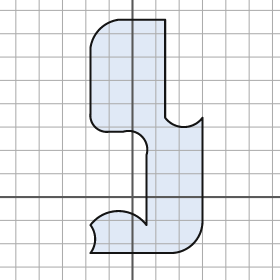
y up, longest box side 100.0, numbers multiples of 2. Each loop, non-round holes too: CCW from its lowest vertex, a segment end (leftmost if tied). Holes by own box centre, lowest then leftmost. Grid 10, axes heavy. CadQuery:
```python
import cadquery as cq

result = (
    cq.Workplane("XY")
    .moveTo(-18.0, -24.0)
    .lineTo(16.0, -24.0)
    .threePointArc((26.0, -20.0), (30.0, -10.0))
    .lineTo(30.0, 34.0)
    .threePointArc((22.0, 30.0), (14.0, 34.0))
    .lineTo(14.0, 76.0)
    .lineTo(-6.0, 76.0)
    .threePointArc((-14.0, 72.0), (-18.0, 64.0))
    .lineTo(-18.0, 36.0)
    .threePointArc((-16.0, 30.0), (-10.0, 28.0))
    .lineTo(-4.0, 28.0)
    .threePointArc((4.0, 26.0), (6.0, 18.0))
    .lineTo(6.0, -12.0)
    .threePointArc((-6.0, -6.0), (-18.0, -12.0))
    .threePointArc((-16.0, -18.0), (-18.0, -24.0))
    .close()
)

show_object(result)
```